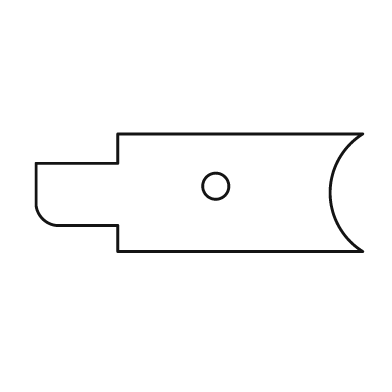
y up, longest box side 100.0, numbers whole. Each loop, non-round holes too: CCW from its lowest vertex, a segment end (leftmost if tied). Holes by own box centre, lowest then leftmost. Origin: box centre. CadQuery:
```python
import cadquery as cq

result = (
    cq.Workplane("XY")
    .moveTo(-25.0, -18.0)
    .lineTo(50.0, -18.0)
    .threePointArc((40.0, 0.0), (50.0, 18.0))
    .lineTo(-25.0, 18.0)
    .lineTo(-25.0, 9.0)
    .lineTo(-50.0, 9.0)
    .lineTo(-50.0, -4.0)
    .threePointArc((-48.0, -8.0), (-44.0, -10.0))
    .lineTo(-25.0, -10.0)
    .close()
    .moveTo(5.0, 2.0)
    .circle(4.0)
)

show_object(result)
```